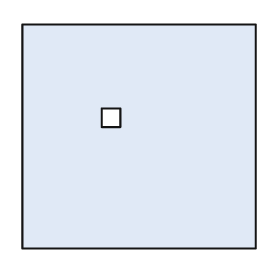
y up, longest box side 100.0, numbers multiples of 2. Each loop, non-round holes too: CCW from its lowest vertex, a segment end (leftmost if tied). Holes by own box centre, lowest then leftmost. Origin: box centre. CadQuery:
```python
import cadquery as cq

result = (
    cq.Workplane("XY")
    .moveTo(-50.0, -48.0)
    .lineTo(50.0, -48.0)
    .lineTo(50.0, 48.0)
    .lineTo(-50.0, 48.0)
    .close()
    .moveTo(-16.0, 4.0)
    .lineTo(-8.0, 4.0)
    .lineTo(-8.0, 12.0)
    .lineTo(-16.0, 12.0)
    .close()
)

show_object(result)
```